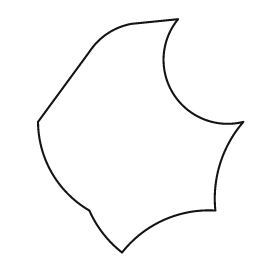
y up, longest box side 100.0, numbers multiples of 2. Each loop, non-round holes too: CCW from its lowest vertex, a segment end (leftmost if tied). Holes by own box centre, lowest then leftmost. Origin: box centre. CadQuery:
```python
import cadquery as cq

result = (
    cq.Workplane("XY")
    .moveTo(-8.0, -50.0)
    .threePointArc((10.0, -36.0), (32.0, -32.0))
    .threePointArc((34.0, -12.0), (44.0, 6.0))
    .threePointArc((14.0, 18.0), (16.0, 50.0))
    .lineTo(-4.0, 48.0)
    .threePointArc((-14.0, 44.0), (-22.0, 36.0))
    .lineTo(-44.0, 6.0)
    .threePointArc((-38.0, -16.0), (-22.0, -32.0))
    .threePointArc((-16.0, -42.0), (-8.0, -50.0))
    .close()
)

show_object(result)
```